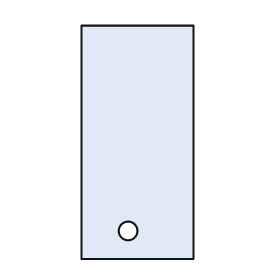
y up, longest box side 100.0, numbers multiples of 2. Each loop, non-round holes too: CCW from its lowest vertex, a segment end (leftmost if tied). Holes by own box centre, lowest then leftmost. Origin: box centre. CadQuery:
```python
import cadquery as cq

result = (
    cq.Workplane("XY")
    .moveTo(-24.0, -50.0)
    .lineTo(24.0, -50.0)
    .lineTo(24.0, 50.0)
    .lineTo(-24.0, 50.0)
    .close()
    .moveTo(-4.0, -38.0)
    .circle(4.0)
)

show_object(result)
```